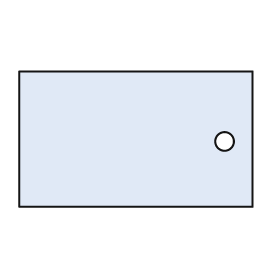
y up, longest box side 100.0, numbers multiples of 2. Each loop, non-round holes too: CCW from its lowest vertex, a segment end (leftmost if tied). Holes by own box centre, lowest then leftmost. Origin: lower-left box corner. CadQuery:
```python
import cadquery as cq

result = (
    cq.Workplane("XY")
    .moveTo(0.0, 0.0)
    .lineTo(100.0, 0.0)
    .lineTo(100.0, 58.0)
    .lineTo(0.0, 58.0)
    .close()
    .moveTo(88.0, 28.0)
    .circle(4.0)
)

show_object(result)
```